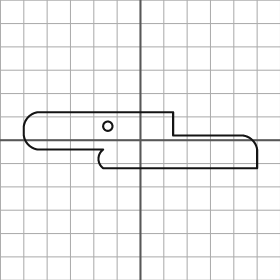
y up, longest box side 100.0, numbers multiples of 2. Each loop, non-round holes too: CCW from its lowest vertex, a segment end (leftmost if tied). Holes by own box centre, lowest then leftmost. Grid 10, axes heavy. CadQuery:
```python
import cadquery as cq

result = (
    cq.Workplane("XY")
    .moveTo(-16.0, -12.0)
    .lineTo(50.0, -12.0)
    .lineTo(50.0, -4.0)
    .threePointArc((48.0, 0.0), (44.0, 2.0))
    .lineTo(14.0, 2.0)
    .lineTo(14.0, 12.0)
    .lineTo(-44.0, 12.0)
    .threePointArc((-48.0, 10.0), (-50.0, 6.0))
    .lineTo(-50.0, 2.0)
    .threePointArc((-48.0, -2.0), (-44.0, -4.0))
    .lineTo(-16.0, -4.0)
    .threePointArc((-18.0, -8.0), (-16.0, -12.0))
    .close()
    .moveTo(-14.0, 6.0)
    .circle(2.0)
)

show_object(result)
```